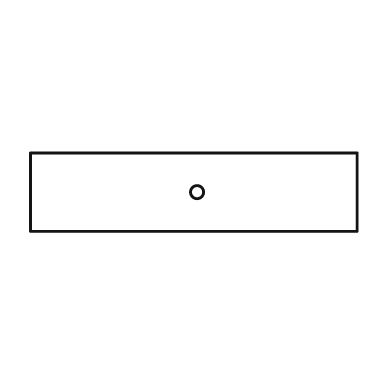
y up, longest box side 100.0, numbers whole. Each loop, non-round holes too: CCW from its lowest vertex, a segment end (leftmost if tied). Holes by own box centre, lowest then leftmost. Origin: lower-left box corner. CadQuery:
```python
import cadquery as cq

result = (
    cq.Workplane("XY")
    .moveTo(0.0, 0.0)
    .lineTo(100.0, 0.0)
    .lineTo(100.0, 24.0)
    .lineTo(0.0, 24.0)
    .close()
    .moveTo(51.0, 12.0)
    .circle(2.0)
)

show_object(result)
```